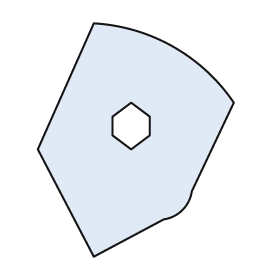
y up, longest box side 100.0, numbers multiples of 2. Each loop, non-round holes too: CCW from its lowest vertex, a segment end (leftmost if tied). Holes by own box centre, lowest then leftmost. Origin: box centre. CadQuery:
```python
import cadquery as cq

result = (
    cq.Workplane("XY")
    .moveTo(-18.0, -50.0)
    .lineTo(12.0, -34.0)
    .threePointArc((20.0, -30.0), (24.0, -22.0))
    .lineTo(42.0, 16.0)
    .threePointArc((16.0, 40.0), (-18.0, 50.0))
    .lineTo(-42.0, -4.0)
    .close()
    .moveTo(-2.0, -4.0)
    .lineTo(6.0, 2.0)
    .lineTo(6.0, 10.0)
    .lineTo(-2.0, 16.0)
    .lineTo(-10.0, 10.0)
    .lineTo(-10.0, 2.0)
    .close()
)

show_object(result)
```